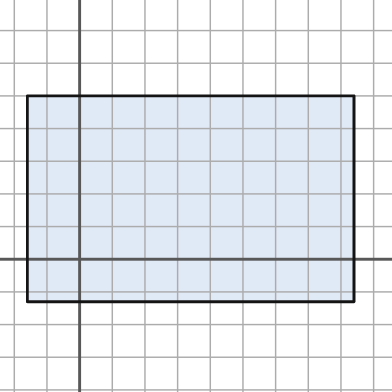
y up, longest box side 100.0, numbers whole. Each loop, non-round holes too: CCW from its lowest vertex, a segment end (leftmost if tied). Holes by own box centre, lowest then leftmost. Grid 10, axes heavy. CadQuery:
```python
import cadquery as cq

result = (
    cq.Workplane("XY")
    .moveTo(-16.0, -13.0)
    .lineTo(84.0, -13.0)
    .lineTo(84.0, 50.0)
    .lineTo(-16.0, 50.0)
    .close()
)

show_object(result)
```